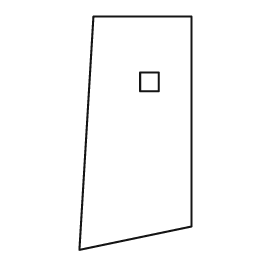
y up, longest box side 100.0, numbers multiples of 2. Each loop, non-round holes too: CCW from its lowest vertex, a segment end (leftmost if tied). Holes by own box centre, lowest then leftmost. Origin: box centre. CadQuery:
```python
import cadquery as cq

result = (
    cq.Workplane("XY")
    .moveTo(-24.0, -50.0)
    .lineTo(24.0, -40.0)
    .lineTo(24.0, 50.0)
    .lineTo(-18.0, 50.0)
    .close()
    .moveTo(2.0, 18.0)
    .lineTo(10.0, 18.0)
    .lineTo(10.0, 26.0)
    .lineTo(2.0, 26.0)
    .close()
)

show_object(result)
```